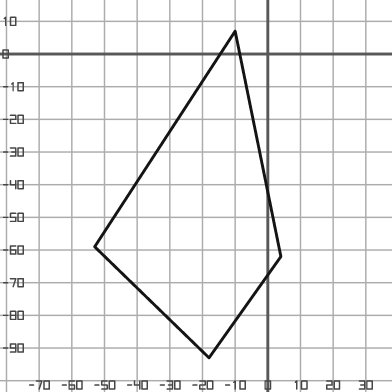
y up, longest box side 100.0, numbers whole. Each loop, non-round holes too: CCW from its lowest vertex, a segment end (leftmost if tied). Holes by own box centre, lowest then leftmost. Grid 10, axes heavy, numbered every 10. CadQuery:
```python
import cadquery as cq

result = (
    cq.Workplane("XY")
    .moveTo(-18.0, -93.0)
    .lineTo(4.0, -62.0)
    .lineTo(-10.0, 7.0)
    .lineTo(-53.0, -59.0)
    .close()
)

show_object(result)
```